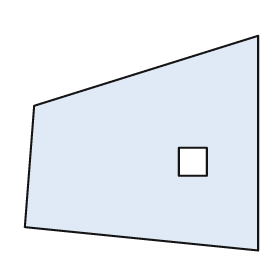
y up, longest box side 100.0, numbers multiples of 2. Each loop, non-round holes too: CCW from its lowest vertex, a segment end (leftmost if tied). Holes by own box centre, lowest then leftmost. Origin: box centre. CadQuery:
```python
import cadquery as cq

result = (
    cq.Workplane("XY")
    .moveTo(50.0, -46.0)
    .lineTo(50.0, 46.0)
    .lineTo(-46.0, 16.0)
    .lineTo(-50.0, -36.0)
    .close()
    .moveTo(16.0, -14.0)
    .lineTo(28.0, -14.0)
    .lineTo(28.0, -2.0)
    .lineTo(16.0, -2.0)
    .close()
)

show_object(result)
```